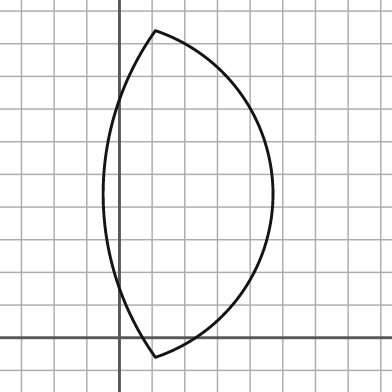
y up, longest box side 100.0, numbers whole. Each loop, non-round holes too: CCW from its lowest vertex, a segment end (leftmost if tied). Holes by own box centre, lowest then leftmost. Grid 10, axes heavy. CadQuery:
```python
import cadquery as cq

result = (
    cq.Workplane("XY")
    .moveTo(11.0, -6.0)
    .threePointArc((47.0, 44.0), (11.0, 94.0))
    .threePointArc((-5.0, 44.0), (11.0, -6.0))
    .close()
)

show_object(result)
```